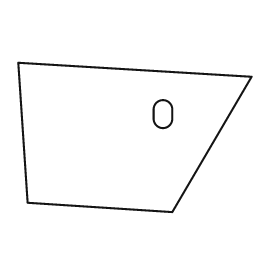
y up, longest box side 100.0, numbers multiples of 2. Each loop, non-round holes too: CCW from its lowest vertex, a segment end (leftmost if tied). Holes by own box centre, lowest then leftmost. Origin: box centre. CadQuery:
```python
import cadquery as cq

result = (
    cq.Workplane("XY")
    .moveTo(16.0, -32.0)
    .lineTo(50.0, 26.0)
    .lineTo(-50.0, 32.0)
    .lineTo(-46.0, -28.0)
    .close()
    .moveTo(8.0, 8.0)
    .threePointArc((12.0, 4.0), (16.0, 8.0))
    .lineTo(16.0, 12.0)
    .threePointArc((12.0, 16.0), (8.0, 12.0))
    .close()
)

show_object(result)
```